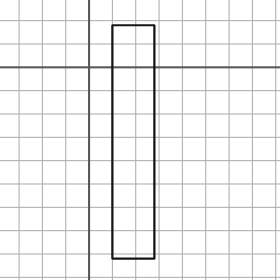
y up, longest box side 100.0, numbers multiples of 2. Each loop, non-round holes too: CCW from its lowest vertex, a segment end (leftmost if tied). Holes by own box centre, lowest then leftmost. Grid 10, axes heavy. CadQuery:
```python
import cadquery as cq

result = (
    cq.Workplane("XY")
    .moveTo(10.0, -82.0)
    .lineTo(28.0, -82.0)
    .lineTo(28.0, 18.0)
    .lineTo(10.0, 18.0)
    .close()
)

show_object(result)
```